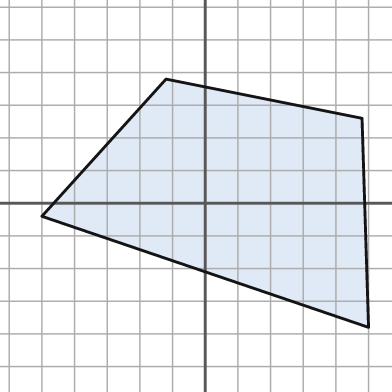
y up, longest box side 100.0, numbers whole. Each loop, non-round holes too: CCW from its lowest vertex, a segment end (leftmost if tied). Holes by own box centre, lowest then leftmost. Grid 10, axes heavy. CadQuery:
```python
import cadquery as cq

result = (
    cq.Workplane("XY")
    .moveTo(50.0, -38.0)
    .lineTo(48.0, 26.0)
    .lineTo(-12.0, 38.0)
    .lineTo(-50.0, -4.0)
    .close()
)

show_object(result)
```